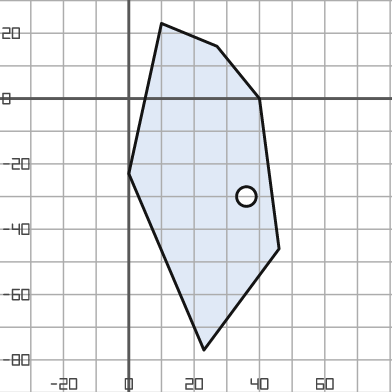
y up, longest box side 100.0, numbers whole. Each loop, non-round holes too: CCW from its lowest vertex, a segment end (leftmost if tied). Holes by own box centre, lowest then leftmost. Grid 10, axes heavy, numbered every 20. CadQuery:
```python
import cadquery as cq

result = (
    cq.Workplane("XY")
    .moveTo(23.0, -77.0)
    .lineTo(46.0, -46.0)
    .lineTo(40.0, 0.0)
    .lineTo(27.0, 16.0)
    .lineTo(10.0, 23.0)
    .lineTo(0.0, -23.0)
    .close()
    .moveTo(36.0, -30.0)
    .circle(3.0)
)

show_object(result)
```